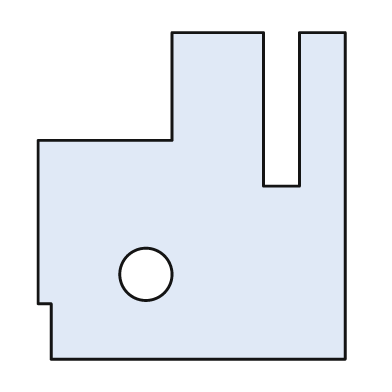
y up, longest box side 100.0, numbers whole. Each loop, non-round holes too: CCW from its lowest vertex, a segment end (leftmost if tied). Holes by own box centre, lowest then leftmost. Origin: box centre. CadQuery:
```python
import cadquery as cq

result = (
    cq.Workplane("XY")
    .moveTo(-43.0, -50.0)
    .lineTo(47.0, -50.0)
    .lineTo(47.0, 50.0)
    .lineTo(33.0, 50.0)
    .lineTo(33.0, 3.0)
    .lineTo(22.0, 3.0)
    .lineTo(22.0, 50.0)
    .lineTo(-6.0, 50.0)
    .lineTo(-6.0, 17.0)
    .lineTo(-47.0, 17.0)
    .lineTo(-47.0, -33.0)
    .lineTo(-43.0, -33.0)
    .close()
    .moveTo(-14.0, -24.0)
    .circle(8.0)
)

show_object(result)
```